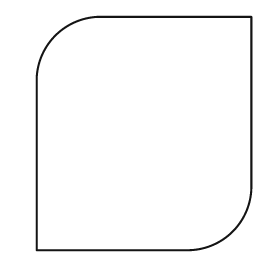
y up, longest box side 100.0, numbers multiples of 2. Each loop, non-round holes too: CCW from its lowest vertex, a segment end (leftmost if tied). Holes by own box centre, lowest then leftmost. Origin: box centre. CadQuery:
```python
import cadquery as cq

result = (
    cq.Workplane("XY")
    .moveTo(-46.0, -50.0)
    .lineTo(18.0, -50.0)
    .threePointArc((38.0, -42.0), (46.0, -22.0))
    .lineTo(46.0, 50.0)
    .lineTo(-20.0, 50.0)
    .threePointArc((-38.0, 42.0), (-46.0, 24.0))
    .close()
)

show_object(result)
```